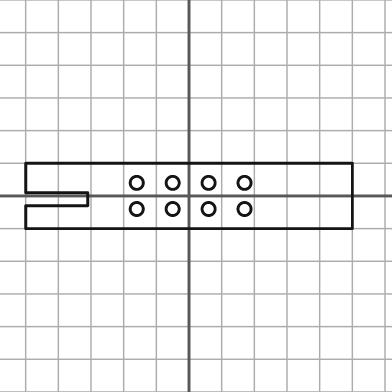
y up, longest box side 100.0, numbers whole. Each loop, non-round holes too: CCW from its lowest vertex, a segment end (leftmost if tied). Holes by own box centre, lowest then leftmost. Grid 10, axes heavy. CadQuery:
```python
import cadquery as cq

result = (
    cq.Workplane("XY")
    .moveTo(-50.0, -10.0)
    .lineTo(50.0, -10.0)
    .lineTo(50.0, 10.0)
    .lineTo(-50.0, 10.0)
    .lineTo(-50.0, 1.0)
    .lineTo(-31.0, 1.0)
    .lineTo(-31.0, -3.0)
    .lineTo(-50.0, -3.0)
    .close()
    .moveTo(-16.0, -4.0)
    .circle(2.0)
    .moveTo(-5.0, -4.0)
    .circle(2.0)
    .moveTo(6.0, -4.0)
    .circle(2.0)
    .moveTo(17.0, -4.0)
    .circle(2.0)
    .moveTo(-16.0, 4.0)
    .circle(2.0)
    .moveTo(-5.0, 4.0)
    .circle(2.0)
    .moveTo(6.0, 4.0)
    .circle(2.0)
    .moveTo(17.0, 4.0)
    .circle(2.0)
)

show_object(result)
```